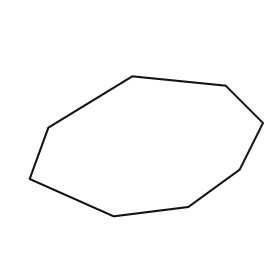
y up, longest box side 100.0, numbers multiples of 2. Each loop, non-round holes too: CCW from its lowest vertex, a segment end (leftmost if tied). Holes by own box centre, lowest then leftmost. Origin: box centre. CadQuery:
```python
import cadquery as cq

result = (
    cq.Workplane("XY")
    .moveTo(-14.0, -30.0)
    .lineTo(18.0, -26.0)
    .lineTo(40.0, -10.0)
    .lineTo(50.0, 10.0)
    .lineTo(34.0, 26.0)
    .lineTo(-6.0, 30.0)
    .lineTo(-42.0, 8.0)
    .lineTo(-50.0, -14.0)
    .close()
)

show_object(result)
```